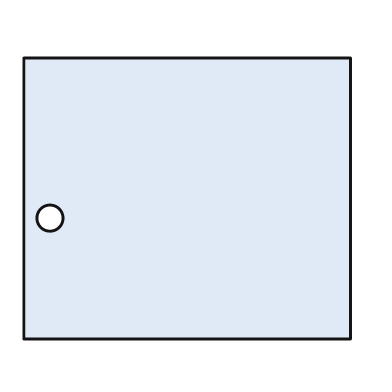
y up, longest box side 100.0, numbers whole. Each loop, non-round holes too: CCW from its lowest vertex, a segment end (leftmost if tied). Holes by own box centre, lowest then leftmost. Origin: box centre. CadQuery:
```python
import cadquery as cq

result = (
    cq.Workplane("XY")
    .moveTo(-50.0, -43.0)
    .lineTo(50.0, -43.0)
    .lineTo(50.0, 43.0)
    .lineTo(-50.0, 43.0)
    .close()
    .moveTo(-42.0, -6.0)
    .circle(4.0)
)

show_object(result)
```